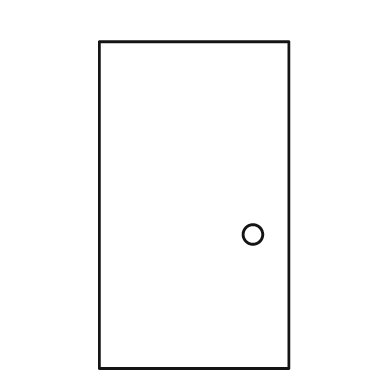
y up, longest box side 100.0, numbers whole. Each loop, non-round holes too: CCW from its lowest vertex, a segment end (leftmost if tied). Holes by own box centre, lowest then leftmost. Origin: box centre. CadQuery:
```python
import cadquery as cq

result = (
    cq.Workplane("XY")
    .moveTo(-29.0, -50.0)
    .lineTo(29.0, -50.0)
    .lineTo(29.0, 50.0)
    .lineTo(-29.0, 50.0)
    .close()
    .moveTo(18.0, -9.0)
    .circle(3.0)
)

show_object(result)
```